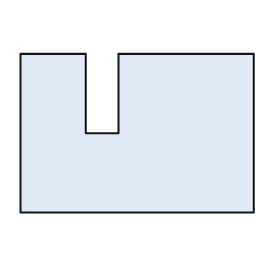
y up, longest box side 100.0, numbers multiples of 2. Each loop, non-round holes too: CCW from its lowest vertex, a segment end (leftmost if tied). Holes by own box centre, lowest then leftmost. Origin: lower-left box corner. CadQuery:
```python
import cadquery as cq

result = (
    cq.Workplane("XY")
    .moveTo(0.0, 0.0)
    .lineTo(100.0, 0.0)
    .lineTo(100.0, 68.0)
    .lineTo(42.0, 68.0)
    .lineTo(42.0, 34.0)
    .lineTo(28.0, 34.0)
    .lineTo(28.0, 68.0)
    .lineTo(0.0, 68.0)
    .close()
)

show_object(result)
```